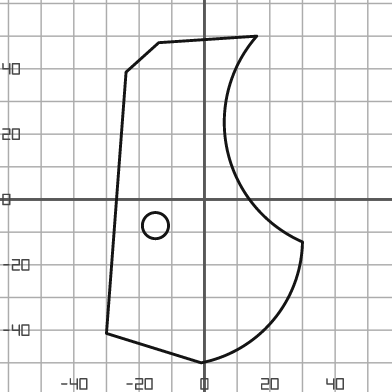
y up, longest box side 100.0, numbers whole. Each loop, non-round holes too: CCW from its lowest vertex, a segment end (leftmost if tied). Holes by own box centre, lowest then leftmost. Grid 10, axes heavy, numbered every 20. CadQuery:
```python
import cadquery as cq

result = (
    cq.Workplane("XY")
    .moveTo(-1.0, -50.0)
    .threePointArc((21.0, -37.0), (30.0, -13.0))
    .threePointArc((7.0, 15.0), (16.0, 50.0))
    .lineTo(-14.0, 48.0)
    .lineTo(-24.0, 39.0)
    .lineTo(-30.0, -41.0)
    .close()
    .moveTo(-15.0, -8.0)
    .circle(4.0)
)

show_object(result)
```